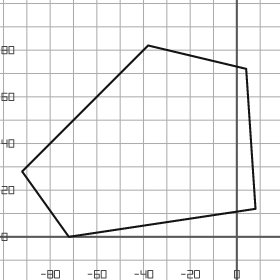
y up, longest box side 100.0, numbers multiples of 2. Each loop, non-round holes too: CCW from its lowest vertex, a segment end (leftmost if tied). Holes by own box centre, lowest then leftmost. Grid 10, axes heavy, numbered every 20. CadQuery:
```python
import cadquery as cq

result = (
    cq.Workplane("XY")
    .moveTo(-72.0, 0.0)
    .lineTo(8.0, 12.0)
    .lineTo(4.0, 72.0)
    .lineTo(-38.0, 82.0)
    .lineTo(-92.0, 28.0)
    .close()
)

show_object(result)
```